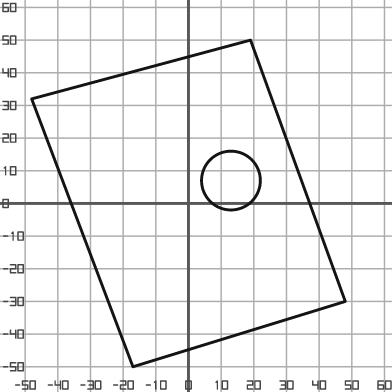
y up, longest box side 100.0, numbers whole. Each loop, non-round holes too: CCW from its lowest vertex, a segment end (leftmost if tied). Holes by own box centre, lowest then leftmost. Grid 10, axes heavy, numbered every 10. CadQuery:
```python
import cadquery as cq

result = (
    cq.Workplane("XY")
    .moveTo(-17.0, -50.0)
    .lineTo(48.0, -30.0)
    .lineTo(19.0, 50.0)
    .lineTo(-48.0, 32.0)
    .close()
    .moveTo(13.0, 7.0)
    .circle(9.0)
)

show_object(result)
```